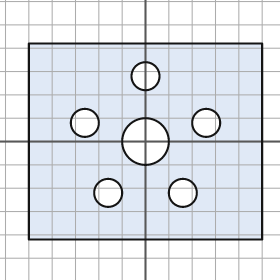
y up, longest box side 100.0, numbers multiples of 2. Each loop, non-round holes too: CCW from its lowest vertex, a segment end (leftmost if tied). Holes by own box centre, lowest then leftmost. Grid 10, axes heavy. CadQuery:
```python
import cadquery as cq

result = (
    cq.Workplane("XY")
    .moveTo(-50.0, -42.0)
    .lineTo(50.0, -42.0)
    .lineTo(50.0, 42.0)
    .lineTo(-50.0, 42.0)
    .close()
    .moveTo(-16.0, -22.0)
    .circle(6.0)
    .moveTo(16.0, -22.0)
    .circle(6.0)
    .moveTo(0.0, 0.0)
    .circle(10.0)
    .moveTo(-26.0, 8.0)
    .circle(6.0)
    .moveTo(26.0, 8.0)
    .circle(6.0)
    .moveTo(0.0, 28.0)
    .circle(6.0)
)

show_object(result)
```